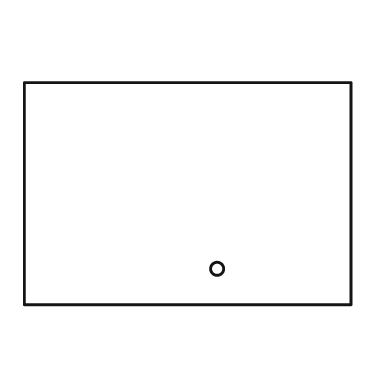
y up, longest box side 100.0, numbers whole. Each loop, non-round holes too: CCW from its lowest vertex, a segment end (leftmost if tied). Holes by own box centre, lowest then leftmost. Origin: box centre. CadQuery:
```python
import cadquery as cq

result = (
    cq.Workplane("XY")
    .moveTo(-50.0, -34.0)
    .lineTo(50.0, -34.0)
    .lineTo(50.0, 34.0)
    .lineTo(-50.0, 34.0)
    .close()
    .moveTo(9.0, -23.0)
    .circle(2.0)
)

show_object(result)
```